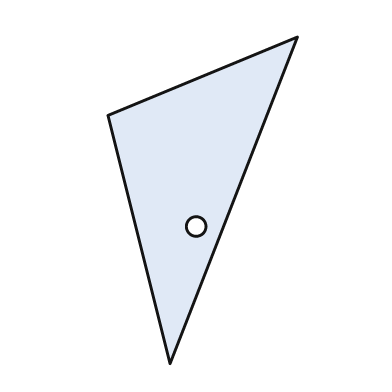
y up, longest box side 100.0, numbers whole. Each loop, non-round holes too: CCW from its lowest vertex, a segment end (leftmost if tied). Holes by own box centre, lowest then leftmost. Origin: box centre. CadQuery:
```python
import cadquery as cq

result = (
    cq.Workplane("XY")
    .moveTo(-10.0, -50.0)
    .lineTo(29.0, 50.0)
    .lineTo(-29.0, 26.0)
    .close()
    .moveTo(-2.0, -8.0)
    .circle(3.0)
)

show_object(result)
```